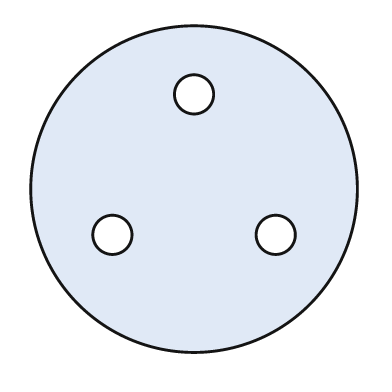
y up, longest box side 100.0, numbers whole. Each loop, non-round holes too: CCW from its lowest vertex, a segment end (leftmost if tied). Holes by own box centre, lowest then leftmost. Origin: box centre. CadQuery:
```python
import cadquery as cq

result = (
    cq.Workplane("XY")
    .moveTo(0.0, 0.0)
    .circle(50.0)
    .moveTo(-25.0, -14.0)
    .circle(6.0)
    .moveTo(25.0, -14.0)
    .circle(6.0)
    .moveTo(0.0, 29.0)
    .circle(6.0)
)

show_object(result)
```